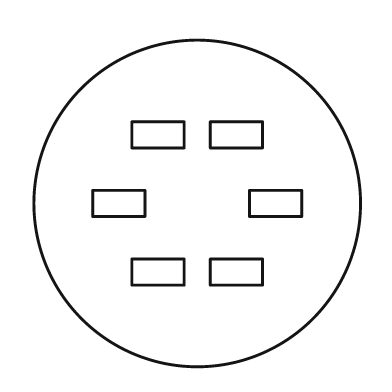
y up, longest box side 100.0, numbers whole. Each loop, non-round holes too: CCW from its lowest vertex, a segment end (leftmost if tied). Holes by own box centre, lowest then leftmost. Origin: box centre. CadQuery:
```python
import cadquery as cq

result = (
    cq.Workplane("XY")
    .moveTo(0.0, 0.0)
    .circle(50.0)
    .moveTo(-20.0, -25.0)
    .lineTo(-4.0, -25.0)
    .lineTo(-4.0, -17.0)
    .lineTo(-20.0, -17.0)
    .close()
    .moveTo(4.0, -25.0)
    .lineTo(20.0, -25.0)
    .lineTo(20.0, -17.0)
    .lineTo(4.0, -17.0)
    .close()
    .moveTo(-32.0, -4.0)
    .lineTo(-16.0, -4.0)
    .lineTo(-16.0, 4.0)
    .lineTo(-32.0, 4.0)
    .close()
    .moveTo(16.0, -4.0)
    .lineTo(32.0, -4.0)
    .lineTo(32.0, 4.0)
    .lineTo(16.0, 4.0)
    .close()
    .moveTo(-20.0, 17.0)
    .lineTo(-4.0, 17.0)
    .lineTo(-4.0, 25.0)
    .lineTo(-20.0, 25.0)
    .close()
    .moveTo(4.0, 17.0)
    .lineTo(20.0, 17.0)
    .lineTo(20.0, 25.0)
    .lineTo(4.0, 25.0)
    .close()
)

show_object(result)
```